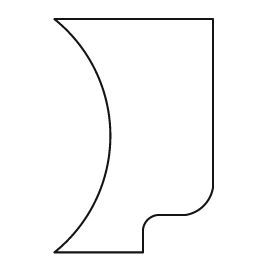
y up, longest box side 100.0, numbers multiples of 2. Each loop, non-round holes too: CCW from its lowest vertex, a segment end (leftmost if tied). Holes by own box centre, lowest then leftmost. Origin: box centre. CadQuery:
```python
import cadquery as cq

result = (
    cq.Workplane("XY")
    .moveTo(-34.0, -50.0)
    .lineTo(4.0, -50.0)
    .lineTo(4.0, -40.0)
    .threePointArc((6.0, -36.0), (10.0, -34.0))
    .lineTo(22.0, -34.0)
    .threePointArc((30.0, -30.0), (34.0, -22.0))
    .lineTo(34.0, 50.0)
    .lineTo(-34.0, 50.0)
    .threePointArc((-10.0, 0.0), (-34.0, -50.0))
    .close()
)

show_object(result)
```